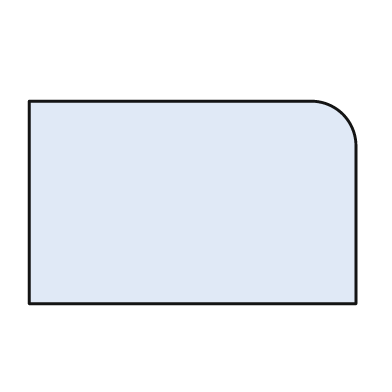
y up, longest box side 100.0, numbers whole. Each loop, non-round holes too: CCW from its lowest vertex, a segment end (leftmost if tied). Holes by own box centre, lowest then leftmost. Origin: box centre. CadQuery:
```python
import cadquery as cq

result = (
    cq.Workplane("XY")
    .moveTo(-50.0, -31.0)
    .lineTo(50.0, -31.0)
    .lineTo(50.0, 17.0)
    .threePointArc((46.0, 27.0), (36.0, 31.0))
    .lineTo(-50.0, 31.0)
    .close()
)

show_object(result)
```